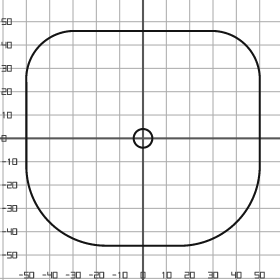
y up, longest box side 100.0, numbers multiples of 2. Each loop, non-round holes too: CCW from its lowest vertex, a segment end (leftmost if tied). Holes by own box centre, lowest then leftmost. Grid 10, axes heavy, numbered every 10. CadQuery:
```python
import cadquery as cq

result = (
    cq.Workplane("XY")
    .moveTo(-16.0, -46.0)
    .lineTo(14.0, -46.0)
    .threePointArc((40.0, -36.0), (50.0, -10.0))
    .lineTo(50.0, 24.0)
    .threePointArc((44.0, 40.0), (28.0, 46.0))
    .lineTo(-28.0, 46.0)
    .threePointArc((-44.0, 40.0), (-50.0, 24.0))
    .lineTo(-50.0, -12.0)
    .threePointArc((-40.0, -36.0), (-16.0, -46.0))
    .close()
    .moveTo(0.0, 0.0)
    .circle(4.0)
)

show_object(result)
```